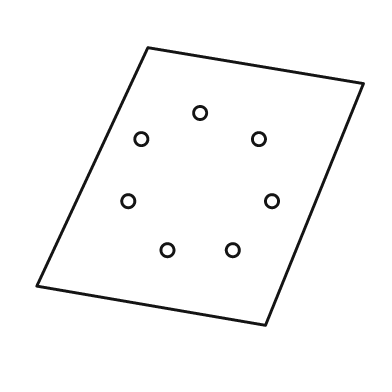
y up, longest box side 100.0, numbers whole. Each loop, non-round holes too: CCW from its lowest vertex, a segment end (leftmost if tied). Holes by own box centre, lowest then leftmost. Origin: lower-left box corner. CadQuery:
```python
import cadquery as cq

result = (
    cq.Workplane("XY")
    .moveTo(70.0, 0.0)
    .lineTo(100.0, 74.0)
    .lineTo(34.0, 85.0)
    .lineTo(0.0, 12.0)
    .close()
    .moveTo(40.0, 23.0)
    .circle(2.0)
    .moveTo(60.0, 23.0)
    .circle(2.0)
    .moveTo(28.0, 38.0)
    .circle(2.0)
    .moveTo(72.0, 38.0)
    .circle(2.0)
    .moveTo(32.0, 57.0)
    .circle(2.0)
    .moveTo(68.0, 57.0)
    .circle(2.0)
    .moveTo(50.0, 65.0)
    .circle(2.0)
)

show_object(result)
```